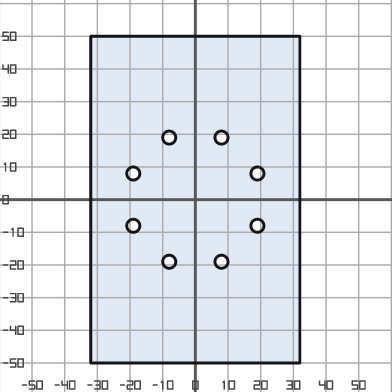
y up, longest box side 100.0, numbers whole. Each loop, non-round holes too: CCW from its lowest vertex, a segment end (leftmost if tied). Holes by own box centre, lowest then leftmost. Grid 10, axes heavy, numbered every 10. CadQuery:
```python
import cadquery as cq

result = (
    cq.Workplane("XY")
    .moveTo(-32.0, -50.0)
    .lineTo(32.0, -50.0)
    .lineTo(32.0, 50.0)
    .lineTo(-32.0, 50.0)
    .close()
    .moveTo(-8.0, -19.0)
    .circle(2.0)
    .moveTo(8.0, -19.0)
    .circle(2.0)
    .moveTo(-19.0, -8.0)
    .circle(2.0)
    .moveTo(19.0, -8.0)
    .circle(2.0)
    .moveTo(-19.0, 8.0)
    .circle(2.0)
    .moveTo(19.0, 8.0)
    .circle(2.0)
    .moveTo(-8.0, 19.0)
    .circle(2.0)
    .moveTo(8.0, 19.0)
    .circle(2.0)
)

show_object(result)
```